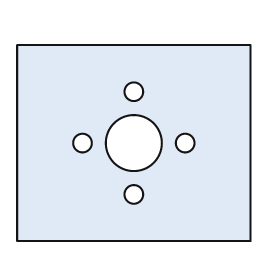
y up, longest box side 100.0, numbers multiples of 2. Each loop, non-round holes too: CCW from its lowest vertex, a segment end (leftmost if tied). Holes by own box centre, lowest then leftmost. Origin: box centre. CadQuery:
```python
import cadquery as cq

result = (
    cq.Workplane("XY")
    .moveTo(-50.0, -42.0)
    .lineTo(50.0, -42.0)
    .lineTo(50.0, 42.0)
    .lineTo(-50.0, 42.0)
    .close()
    .moveTo(0.0, -22.0)
    .circle(4.0)
    .moveTo(-22.0, 0.0)
    .circle(4.0)
    .moveTo(0.0, 0.0)
    .circle(12.0)
    .moveTo(22.0, 0.0)
    .circle(4.0)
    .moveTo(0.0, 22.0)
    .circle(4.0)
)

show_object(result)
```